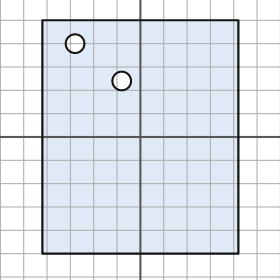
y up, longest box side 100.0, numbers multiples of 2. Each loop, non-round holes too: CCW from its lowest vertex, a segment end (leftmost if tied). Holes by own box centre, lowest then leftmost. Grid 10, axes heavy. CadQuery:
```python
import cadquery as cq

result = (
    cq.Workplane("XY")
    .moveTo(-42.0, -50.0)
    .lineTo(42.0, -50.0)
    .lineTo(42.0, 50.0)
    .lineTo(-42.0, 50.0)
    .close()
    .moveTo(-8.0, 24.0)
    .circle(4.0)
    .moveTo(-28.0, 40.0)
    .circle(4.0)
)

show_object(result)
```